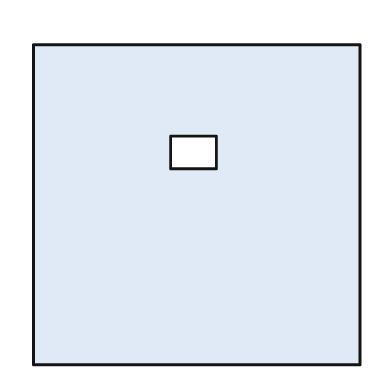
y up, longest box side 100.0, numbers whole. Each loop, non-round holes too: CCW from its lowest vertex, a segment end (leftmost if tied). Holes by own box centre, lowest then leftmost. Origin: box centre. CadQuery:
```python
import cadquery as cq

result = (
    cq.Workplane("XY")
    .moveTo(-50.0, -49.0)
    .lineTo(50.0, -49.0)
    .lineTo(50.0, 49.0)
    .lineTo(-50.0, 49.0)
    .close()
    .moveTo(-8.0, 11.0)
    .lineTo(6.0, 11.0)
    .lineTo(6.0, 21.0)
    .lineTo(-8.0, 21.0)
    .close()
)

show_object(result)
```